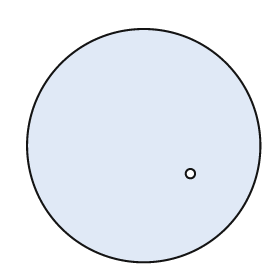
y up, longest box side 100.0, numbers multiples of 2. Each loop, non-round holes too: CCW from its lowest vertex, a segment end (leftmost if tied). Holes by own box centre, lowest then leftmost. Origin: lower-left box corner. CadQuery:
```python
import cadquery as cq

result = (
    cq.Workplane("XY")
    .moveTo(50.0, 50.0)
    .circle(50.0)
    .moveTo(70.0, 38.0)
    .circle(2.0)
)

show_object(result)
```